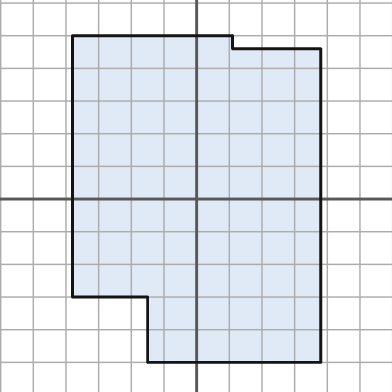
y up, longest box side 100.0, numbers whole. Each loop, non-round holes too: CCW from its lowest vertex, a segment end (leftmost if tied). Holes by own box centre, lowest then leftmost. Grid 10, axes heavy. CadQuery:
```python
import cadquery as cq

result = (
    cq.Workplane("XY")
    .moveTo(-15.0, -50.0)
    .lineTo(38.0, -50.0)
    .lineTo(38.0, 46.0)
    .lineTo(11.0, 46.0)
    .lineTo(11.0, 50.0)
    .lineTo(-38.0, 50.0)
    .lineTo(-38.0, -30.0)
    .lineTo(-15.0, -30.0)
    .close()
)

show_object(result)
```